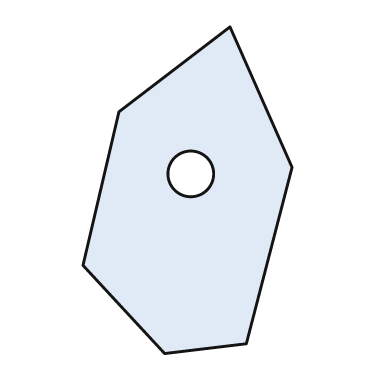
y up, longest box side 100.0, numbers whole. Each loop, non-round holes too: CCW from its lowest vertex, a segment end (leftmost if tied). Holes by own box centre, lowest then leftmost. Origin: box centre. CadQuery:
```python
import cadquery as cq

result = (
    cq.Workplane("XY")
    .moveTo(-7.0, -50.0)
    .lineTo(18.0, -47.0)
    .lineTo(32.0, 7.0)
    .lineTo(13.0, 50.0)
    .lineTo(-21.0, 24.0)
    .lineTo(-32.0, -23.0)
    .close()
    .moveTo(1.0, 5.0)
    .circle(7.0)
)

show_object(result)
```